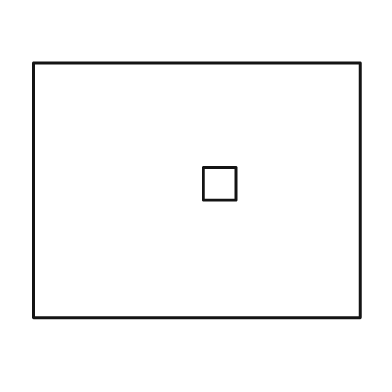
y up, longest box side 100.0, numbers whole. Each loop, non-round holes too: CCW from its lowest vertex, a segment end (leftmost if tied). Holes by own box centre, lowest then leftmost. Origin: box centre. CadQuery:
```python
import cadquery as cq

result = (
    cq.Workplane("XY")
    .moveTo(-50.0, -39.0)
    .lineTo(50.0, -39.0)
    .lineTo(50.0, 39.0)
    .lineTo(-50.0, 39.0)
    .close()
    .moveTo(2.0, -3.0)
    .lineTo(12.0, -3.0)
    .lineTo(12.0, 7.0)
    .lineTo(2.0, 7.0)
    .close()
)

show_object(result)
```